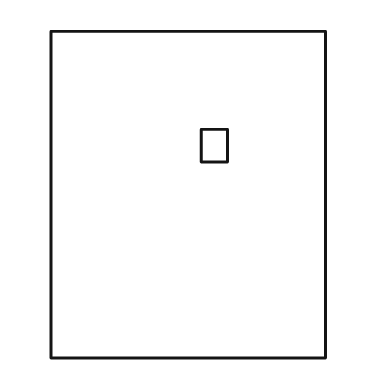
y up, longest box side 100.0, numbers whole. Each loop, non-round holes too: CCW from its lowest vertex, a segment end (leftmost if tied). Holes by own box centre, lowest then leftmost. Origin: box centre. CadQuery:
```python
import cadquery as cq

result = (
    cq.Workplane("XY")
    .moveTo(-42.0, -50.0)
    .lineTo(42.0, -50.0)
    .lineTo(42.0, 50.0)
    .lineTo(-42.0, 50.0)
    .close()
    .moveTo(4.0, 10.0)
    .lineTo(12.0, 10.0)
    .lineTo(12.0, 20.0)
    .lineTo(4.0, 20.0)
    .close()
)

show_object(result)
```